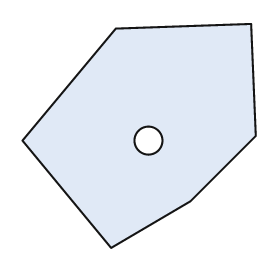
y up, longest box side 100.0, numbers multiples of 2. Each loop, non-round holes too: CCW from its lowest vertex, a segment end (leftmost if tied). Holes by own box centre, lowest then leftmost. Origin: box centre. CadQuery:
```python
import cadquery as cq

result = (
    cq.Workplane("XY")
    .moveTo(-12.0, -48.0)
    .lineTo(22.0, -28.0)
    .lineTo(50.0, 0.0)
    .lineTo(48.0, 48.0)
    .lineTo(-10.0, 46.0)
    .lineTo(-50.0, -2.0)
    .close()
    .moveTo(4.0, -2.0)
    .circle(6.0)
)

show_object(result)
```